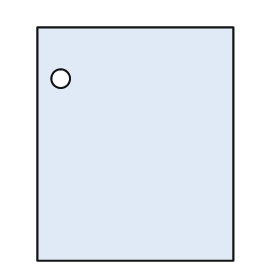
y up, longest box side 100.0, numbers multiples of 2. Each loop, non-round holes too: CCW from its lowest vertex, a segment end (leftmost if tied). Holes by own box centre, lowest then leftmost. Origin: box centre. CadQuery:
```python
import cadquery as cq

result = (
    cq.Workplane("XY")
    .moveTo(-42.0, -50.0)
    .lineTo(42.0, -50.0)
    .lineTo(42.0, 50.0)
    .lineTo(-42.0, 50.0)
    .close()
    .moveTo(-32.0, 28.0)
    .circle(4.0)
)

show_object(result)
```